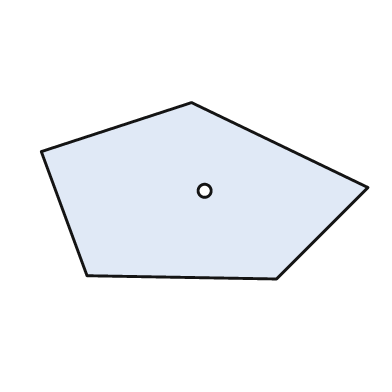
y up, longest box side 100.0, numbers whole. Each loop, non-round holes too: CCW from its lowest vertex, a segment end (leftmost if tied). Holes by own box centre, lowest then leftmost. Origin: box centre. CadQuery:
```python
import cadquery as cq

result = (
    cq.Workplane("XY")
    .moveTo(22.0, -27.0)
    .lineTo(50.0, 1.0)
    .lineTo(-4.0, 27.0)
    .lineTo(-50.0, 12.0)
    .lineTo(-36.0, -26.0)
    .close()
    .moveTo(0.0, 0.0)
    .circle(2.0)
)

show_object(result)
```